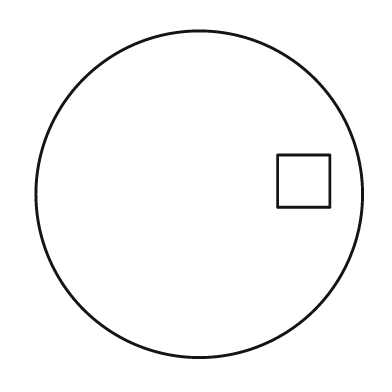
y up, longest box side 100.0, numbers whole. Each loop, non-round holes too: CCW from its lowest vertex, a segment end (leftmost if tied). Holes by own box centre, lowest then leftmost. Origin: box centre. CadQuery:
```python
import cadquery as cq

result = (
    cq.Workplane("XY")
    .moveTo(0.0, 0.0)
    .circle(50.0)
    .moveTo(24.0, -4.0)
    .lineTo(40.0, -4.0)
    .lineTo(40.0, 12.0)
    .lineTo(24.0, 12.0)
    .close()
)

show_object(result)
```